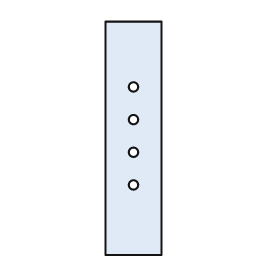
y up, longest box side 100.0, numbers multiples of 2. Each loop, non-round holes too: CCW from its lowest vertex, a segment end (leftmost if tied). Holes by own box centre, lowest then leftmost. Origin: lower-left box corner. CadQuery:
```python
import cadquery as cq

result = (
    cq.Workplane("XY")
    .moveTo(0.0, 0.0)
    .lineTo(24.0, 0.0)
    .lineTo(24.0, 100.0)
    .lineTo(0.0, 100.0)
    .close()
    .moveTo(12.0, 30.0)
    .circle(2.0)
    .moveTo(12.0, 44.0)
    .circle(2.0)
    .moveTo(12.0, 58.0)
    .circle(2.0)
    .moveTo(12.0, 72.0)
    .circle(2.0)
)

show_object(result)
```